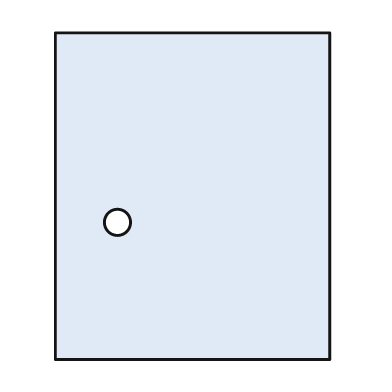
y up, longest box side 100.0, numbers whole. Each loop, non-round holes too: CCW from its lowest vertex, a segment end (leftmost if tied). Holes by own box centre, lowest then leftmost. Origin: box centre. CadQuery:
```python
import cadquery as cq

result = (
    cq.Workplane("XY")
    .moveTo(-42.0, -50.0)
    .lineTo(42.0, -50.0)
    .lineTo(42.0, 50.0)
    .lineTo(-42.0, 50.0)
    .close()
    .moveTo(-23.0, -8.0)
    .circle(4.0)
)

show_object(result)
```